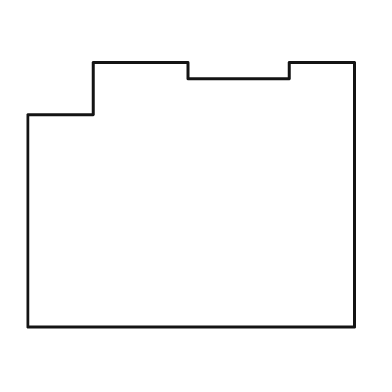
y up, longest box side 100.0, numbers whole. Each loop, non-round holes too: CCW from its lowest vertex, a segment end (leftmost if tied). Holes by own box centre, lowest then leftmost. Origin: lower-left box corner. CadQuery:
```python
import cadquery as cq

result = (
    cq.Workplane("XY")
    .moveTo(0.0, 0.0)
    .lineTo(100.0, 0.0)
    .lineTo(100.0, 81.0)
    .lineTo(80.0, 81.0)
    .lineTo(80.0, 76.0)
    .lineTo(49.0, 76.0)
    .lineTo(49.0, 81.0)
    .lineTo(20.0, 81.0)
    .lineTo(20.0, 65.0)
    .lineTo(0.0, 65.0)
    .close()
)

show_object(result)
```